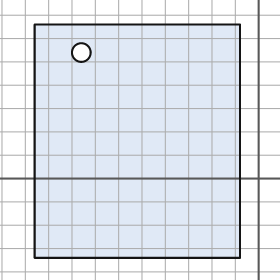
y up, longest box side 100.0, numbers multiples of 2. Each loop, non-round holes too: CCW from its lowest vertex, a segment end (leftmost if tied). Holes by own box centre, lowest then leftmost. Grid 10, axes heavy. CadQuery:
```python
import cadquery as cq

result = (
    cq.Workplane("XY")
    .moveTo(-96.0, -34.0)
    .lineTo(-8.0, -34.0)
    .lineTo(-8.0, 66.0)
    .lineTo(-96.0, 66.0)
    .close()
    .moveTo(-76.0, 54.0)
    .circle(4.0)
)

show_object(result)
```